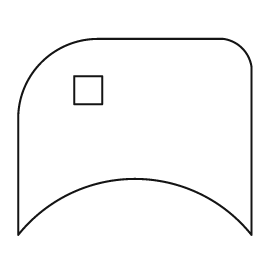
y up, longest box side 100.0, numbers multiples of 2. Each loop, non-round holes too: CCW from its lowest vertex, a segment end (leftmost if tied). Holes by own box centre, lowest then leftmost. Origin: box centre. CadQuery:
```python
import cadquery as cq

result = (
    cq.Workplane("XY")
    .moveTo(-50.0, -42.0)
    .threePointArc((0.0, -18.0), (50.0, -42.0))
    .lineTo(50.0, 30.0)
    .threePointArc((46.0, 38.0), (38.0, 42.0))
    .lineTo(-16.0, 42.0)
    .threePointArc((-40.0, 32.0), (-50.0, 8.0))
    .close()
    .moveTo(-26.0, 14.0)
    .lineTo(-14.0, 14.0)
    .lineTo(-14.0, 26.0)
    .lineTo(-26.0, 26.0)
    .close()
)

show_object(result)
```